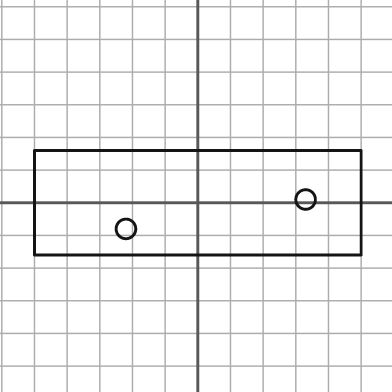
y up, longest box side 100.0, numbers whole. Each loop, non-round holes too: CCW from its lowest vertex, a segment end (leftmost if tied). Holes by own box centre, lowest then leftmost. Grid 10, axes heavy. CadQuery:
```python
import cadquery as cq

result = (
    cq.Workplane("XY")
    .moveTo(-50.0, -16.0)
    .lineTo(50.0, -16.0)
    .lineTo(50.0, 16.0)
    .lineTo(-50.0, 16.0)
    .close()
    .moveTo(-22.0, -8.0)
    .circle(3.0)
    .moveTo(33.0, 1.0)
    .circle(3.0)
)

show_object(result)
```